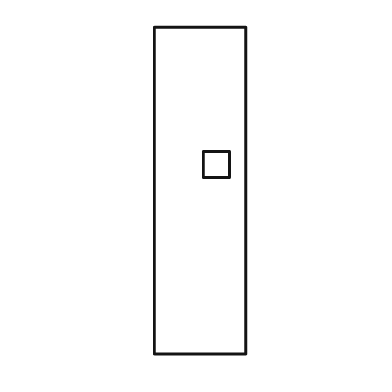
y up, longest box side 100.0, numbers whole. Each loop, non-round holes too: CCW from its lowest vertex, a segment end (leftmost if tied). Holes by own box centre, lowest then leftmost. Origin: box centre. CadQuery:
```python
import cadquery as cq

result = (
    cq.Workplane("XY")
    .moveTo(-14.0, -50.0)
    .lineTo(14.0, -50.0)
    .lineTo(14.0, 50.0)
    .lineTo(-14.0, 50.0)
    .close()
    .moveTo(1.0, 4.0)
    .lineTo(9.0, 4.0)
    .lineTo(9.0, 12.0)
    .lineTo(1.0, 12.0)
    .close()
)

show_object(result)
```